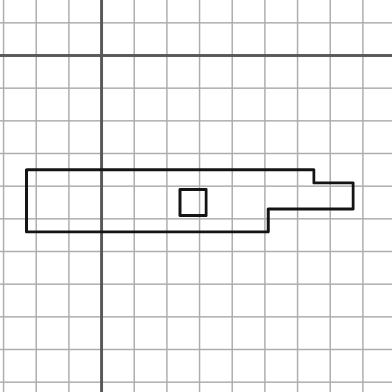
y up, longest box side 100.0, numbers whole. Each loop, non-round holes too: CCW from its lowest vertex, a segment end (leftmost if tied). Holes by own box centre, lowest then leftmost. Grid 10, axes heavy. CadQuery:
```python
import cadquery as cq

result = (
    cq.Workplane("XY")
    .moveTo(-23.0, -54.0)
    .lineTo(51.0, -54.0)
    .lineTo(51.0, -47.0)
    .lineTo(77.0, -47.0)
    .lineTo(77.0, -39.0)
    .lineTo(65.0, -39.0)
    .lineTo(65.0, -35.0)
    .lineTo(-23.0, -35.0)
    .close()
    .moveTo(24.0, -49.0)
    .lineTo(32.0, -49.0)
    .lineTo(32.0, -41.0)
    .lineTo(24.0, -41.0)
    .close()
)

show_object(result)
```